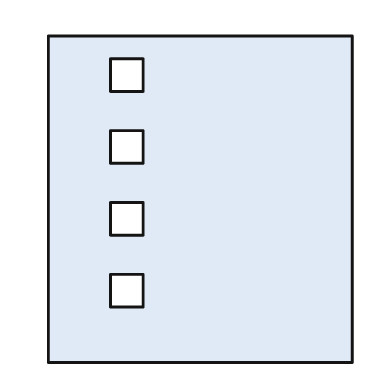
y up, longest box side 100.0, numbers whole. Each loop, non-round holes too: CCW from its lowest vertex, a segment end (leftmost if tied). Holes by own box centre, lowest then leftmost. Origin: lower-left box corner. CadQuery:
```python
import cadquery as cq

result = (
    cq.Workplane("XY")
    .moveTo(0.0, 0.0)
    .lineTo(93.0, 0.0)
    .lineTo(93.0, 100.0)
    .lineTo(0.0, 100.0)
    .close()
    .moveTo(19.0, 17.0)
    .lineTo(29.0, 17.0)
    .lineTo(29.0, 27.0)
    .lineTo(19.0, 27.0)
    .close()
    .moveTo(19.0, 39.0)
    .lineTo(29.0, 39.0)
    .lineTo(29.0, 49.0)
    .lineTo(19.0, 49.0)
    .close()
    .moveTo(19.0, 61.0)
    .lineTo(29.0, 61.0)
    .lineTo(29.0, 71.0)
    .lineTo(19.0, 71.0)
    .close()
    .moveTo(19.0, 83.0)
    .lineTo(29.0, 83.0)
    .lineTo(29.0, 93.0)
    .lineTo(19.0, 93.0)
    .close()
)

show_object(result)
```